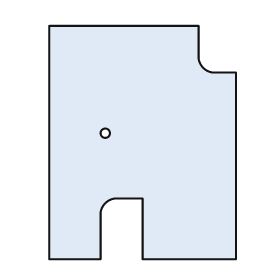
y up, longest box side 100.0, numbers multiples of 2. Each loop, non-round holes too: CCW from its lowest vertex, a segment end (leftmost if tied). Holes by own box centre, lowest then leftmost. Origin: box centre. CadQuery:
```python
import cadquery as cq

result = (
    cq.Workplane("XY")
    .moveTo(-40.0, -50.0)
    .lineTo(-18.0, -50.0)
    .lineTo(-18.0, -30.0)
    .threePointArc((-16.0, -26.0), (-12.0, -24.0))
    .lineTo(0.0, -24.0)
    .lineTo(0.0, -50.0)
    .lineTo(40.0, -50.0)
    .lineTo(40.0, 30.0)
    .lineTo(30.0, 30.0)
    .threePointArc((26.0, 32.0), (24.0, 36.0))
    .lineTo(24.0, 50.0)
    .lineTo(-40.0, 50.0)
    .close()
    .moveTo(-16.0, 4.0)
    .circle(2.0)
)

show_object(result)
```